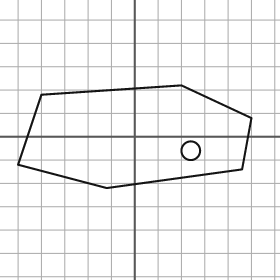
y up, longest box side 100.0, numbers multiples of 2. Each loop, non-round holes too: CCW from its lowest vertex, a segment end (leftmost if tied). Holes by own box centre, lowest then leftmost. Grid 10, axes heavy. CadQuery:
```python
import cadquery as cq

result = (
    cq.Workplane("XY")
    .moveTo(-12.0, -22.0)
    .lineTo(46.0, -14.0)
    .lineTo(50.0, 8.0)
    .lineTo(20.0, 22.0)
    .lineTo(-40.0, 18.0)
    .lineTo(-50.0, -12.0)
    .close()
    .moveTo(24.0, -6.0)
    .circle(4.0)
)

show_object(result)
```